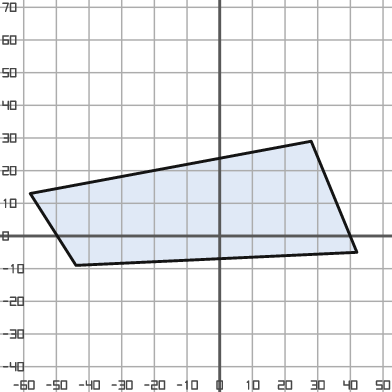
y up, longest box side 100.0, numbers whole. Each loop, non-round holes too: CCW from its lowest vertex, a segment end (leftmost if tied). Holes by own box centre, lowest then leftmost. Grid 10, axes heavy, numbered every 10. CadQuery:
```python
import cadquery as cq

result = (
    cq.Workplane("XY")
    .moveTo(-44.0, -9.0)
    .lineTo(42.0, -5.0)
    .lineTo(28.0, 29.0)
    .lineTo(-58.0, 13.0)
    .close()
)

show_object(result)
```